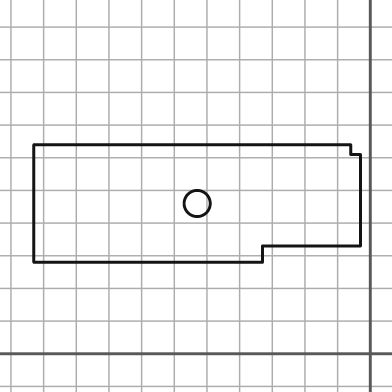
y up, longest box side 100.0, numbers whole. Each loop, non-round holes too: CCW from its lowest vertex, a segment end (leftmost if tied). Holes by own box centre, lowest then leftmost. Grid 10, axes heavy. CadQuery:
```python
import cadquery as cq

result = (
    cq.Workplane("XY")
    .moveTo(-103.0, 28.0)
    .lineTo(-33.0, 28.0)
    .lineTo(-33.0, 33.0)
    .lineTo(-3.0, 33.0)
    .lineTo(-3.0, 61.0)
    .lineTo(-6.0, 61.0)
    .lineTo(-6.0, 64.0)
    .lineTo(-103.0, 64.0)
    .close()
    .moveTo(-53.0, 46.0)
    .circle(4.0)
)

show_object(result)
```